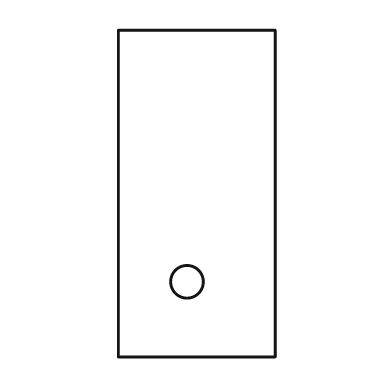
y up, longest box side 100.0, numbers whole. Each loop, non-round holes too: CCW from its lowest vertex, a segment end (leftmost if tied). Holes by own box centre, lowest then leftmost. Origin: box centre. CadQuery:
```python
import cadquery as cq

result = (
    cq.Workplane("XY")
    .moveTo(-24.0, -50.0)
    .lineTo(24.0, -50.0)
    .lineTo(24.0, 50.0)
    .lineTo(-24.0, 50.0)
    .close()
    .moveTo(-3.0, -27.0)
    .circle(5.0)
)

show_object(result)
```